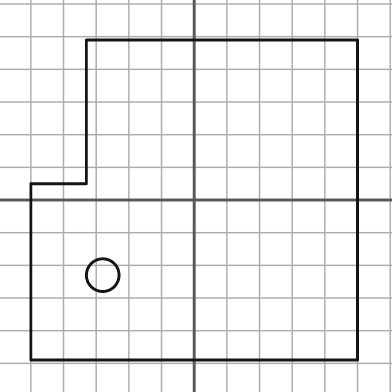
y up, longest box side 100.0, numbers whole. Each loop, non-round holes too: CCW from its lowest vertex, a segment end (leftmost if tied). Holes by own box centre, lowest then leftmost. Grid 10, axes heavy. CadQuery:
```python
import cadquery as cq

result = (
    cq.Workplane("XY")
    .moveTo(-50.0, -49.0)
    .lineTo(50.0, -49.0)
    .lineTo(50.0, 49.0)
    .lineTo(-33.0, 49.0)
    .lineTo(-33.0, 5.0)
    .lineTo(-50.0, 5.0)
    .close()
    .moveTo(-28.0, -23.0)
    .circle(5.0)
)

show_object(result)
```